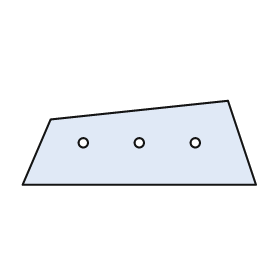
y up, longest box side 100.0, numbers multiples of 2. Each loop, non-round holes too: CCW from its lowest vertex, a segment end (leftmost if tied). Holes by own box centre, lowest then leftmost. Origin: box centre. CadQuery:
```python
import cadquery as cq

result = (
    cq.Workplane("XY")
    .moveTo(-50.0, -18.0)
    .lineTo(50.0, -18.0)
    .lineTo(38.0, 18.0)
    .lineTo(-38.0, 10.0)
    .close()
    .moveTo(-24.0, 0.0)
    .circle(2.0)
    .moveTo(0.0, 0.0)
    .circle(2.0)
    .moveTo(24.0, 0.0)
    .circle(2.0)
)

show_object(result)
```